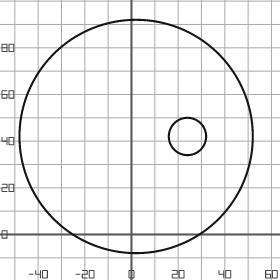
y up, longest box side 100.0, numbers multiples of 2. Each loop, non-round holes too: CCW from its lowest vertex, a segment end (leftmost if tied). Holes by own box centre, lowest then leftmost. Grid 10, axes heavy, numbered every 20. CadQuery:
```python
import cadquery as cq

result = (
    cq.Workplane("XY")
    .moveTo(2.0, 42.0)
    .circle(50.0)
    .moveTo(24.0, 42.0)
    .circle(8.0)
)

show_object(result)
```